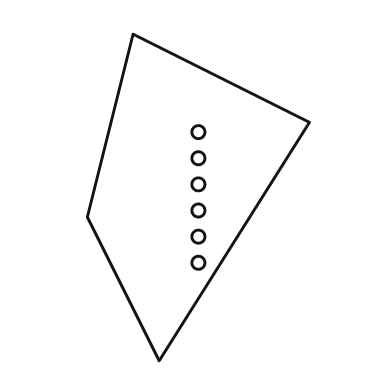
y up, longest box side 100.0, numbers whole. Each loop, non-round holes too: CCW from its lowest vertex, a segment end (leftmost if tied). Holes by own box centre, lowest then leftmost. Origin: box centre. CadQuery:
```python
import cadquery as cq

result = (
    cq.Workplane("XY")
    .moveTo(-12.0, -50.0)
    .lineTo(34.0, 23.0)
    .lineTo(-20.0, 50.0)
    .lineTo(-34.0, -6.0)
    .close()
    .moveTo(0.0, -20.0)
    .circle(2.0)
    .moveTo(0.0, -12.0)
    .circle(2.0)
    .moveTo(0.0, -4.0)
    .circle(2.0)
    .moveTo(0.0, 4.0)
    .circle(2.0)
    .moveTo(0.0, 12.0)
    .circle(2.0)
    .moveTo(0.0, 20.0)
    .circle(2.0)
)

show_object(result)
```